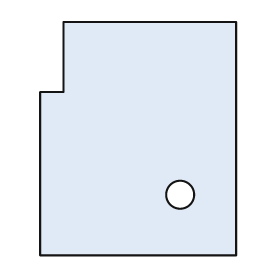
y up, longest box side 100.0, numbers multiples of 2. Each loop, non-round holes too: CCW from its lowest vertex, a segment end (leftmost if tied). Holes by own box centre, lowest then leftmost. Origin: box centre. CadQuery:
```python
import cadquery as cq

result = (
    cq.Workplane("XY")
    .moveTo(-42.0, -50.0)
    .lineTo(42.0, -50.0)
    .lineTo(42.0, 50.0)
    .lineTo(-32.0, 50.0)
    .lineTo(-32.0, 20.0)
    .lineTo(-42.0, 20.0)
    .close()
    .moveTo(18.0, -24.0)
    .circle(6.0)
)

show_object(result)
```